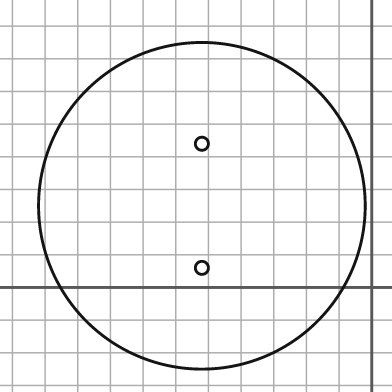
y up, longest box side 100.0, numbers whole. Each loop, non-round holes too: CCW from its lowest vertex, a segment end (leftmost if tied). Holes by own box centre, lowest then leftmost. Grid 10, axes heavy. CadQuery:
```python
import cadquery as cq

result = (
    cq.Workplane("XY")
    .moveTo(-52.0, 25.0)
    .circle(50.0)
    .moveTo(-52.0, 6.0)
    .circle(2.0)
    .moveTo(-52.0, 44.0)
    .circle(2.0)
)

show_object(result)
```